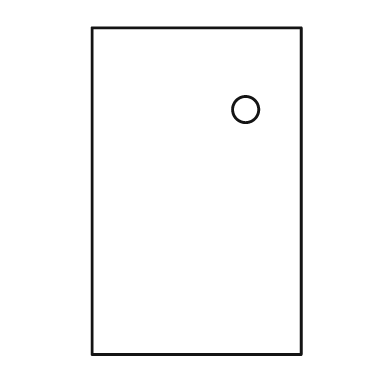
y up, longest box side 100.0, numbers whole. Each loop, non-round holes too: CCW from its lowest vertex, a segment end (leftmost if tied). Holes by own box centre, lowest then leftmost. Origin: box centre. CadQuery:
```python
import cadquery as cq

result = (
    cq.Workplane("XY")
    .moveTo(-32.0, -50.0)
    .lineTo(32.0, -50.0)
    .lineTo(32.0, 50.0)
    .lineTo(-32.0, 50.0)
    .close()
    .moveTo(15.0, 25.0)
    .circle(4.0)
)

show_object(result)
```